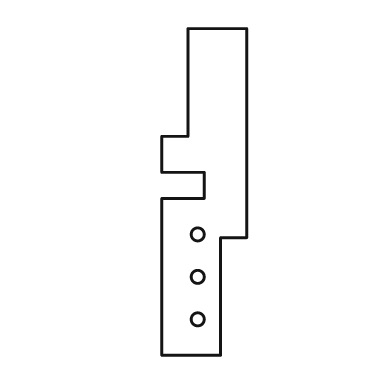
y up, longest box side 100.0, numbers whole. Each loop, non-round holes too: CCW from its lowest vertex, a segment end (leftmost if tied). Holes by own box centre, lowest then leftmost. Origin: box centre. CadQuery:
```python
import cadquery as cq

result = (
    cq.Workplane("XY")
    .moveTo(-13.0, -50.0)
    .lineTo(5.0, -50.0)
    .lineTo(5.0, -14.0)
    .lineTo(13.0, -14.0)
    .lineTo(13.0, 50.0)
    .lineTo(-5.0, 50.0)
    .lineTo(-5.0, 17.0)
    .lineTo(-13.0, 17.0)
    .lineTo(-13.0, 6.0)
    .lineTo(0.0, 6.0)
    .lineTo(0.0, -2.0)
    .lineTo(-13.0, -2.0)
    .close()
    .moveTo(-2.0, -39.0)
    .circle(2.0)
    .moveTo(-2.0, -26.0)
    .circle(2.0)
    .moveTo(-2.0, -13.0)
    .circle(2.0)
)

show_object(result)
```